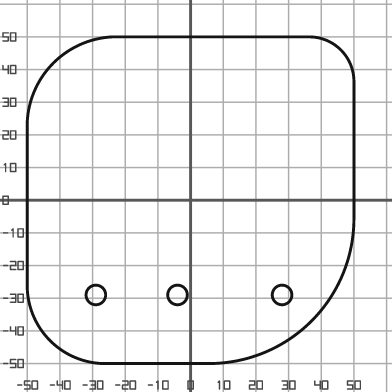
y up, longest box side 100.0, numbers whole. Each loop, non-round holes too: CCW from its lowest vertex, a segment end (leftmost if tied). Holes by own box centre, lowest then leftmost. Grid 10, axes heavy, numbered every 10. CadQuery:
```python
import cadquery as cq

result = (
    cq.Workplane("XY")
    .moveTo(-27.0, -50.0)
    .lineTo(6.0, -50.0)
    .threePointArc((37.0, -37.0), (50.0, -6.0))
    .lineTo(50.0, 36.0)
    .threePointArc((46.0, 46.0), (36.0, 50.0))
    .lineTo(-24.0, 50.0)
    .threePointArc((-42.0, 42.0), (-50.0, 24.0))
    .lineTo(-50.0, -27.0)
    .threePointArc((-43.0, -43.0), (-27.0, -50.0))
    .close()
    .moveTo(-29.0, -29.0)
    .circle(3.0)
    .moveTo(-4.0, -29.0)
    .circle(3.0)
    .moveTo(28.0, -29.0)
    .circle(3.0)
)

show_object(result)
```